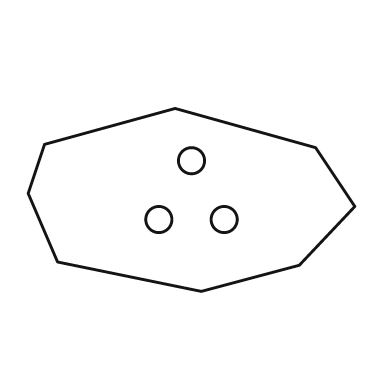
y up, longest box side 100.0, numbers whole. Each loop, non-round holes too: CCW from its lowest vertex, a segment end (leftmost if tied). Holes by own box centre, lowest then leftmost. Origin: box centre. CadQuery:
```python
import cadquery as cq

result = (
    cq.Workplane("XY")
    .moveTo(3.0, -28.0)
    .lineTo(33.0, -20.0)
    .lineTo(50.0, -2.0)
    .lineTo(38.0, 16.0)
    .lineTo(-5.0, 28.0)
    .lineTo(-45.0, 17.0)
    .lineTo(-50.0, 2.0)
    .lineTo(-41.0, -19.0)
    .close()
    .moveTo(-10.0, -6.0)
    .circle(4.0)
    .moveTo(10.0, -6.0)
    .circle(4.0)
    .moveTo(0.0, 12.0)
    .circle(4.0)
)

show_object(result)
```